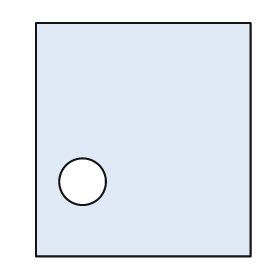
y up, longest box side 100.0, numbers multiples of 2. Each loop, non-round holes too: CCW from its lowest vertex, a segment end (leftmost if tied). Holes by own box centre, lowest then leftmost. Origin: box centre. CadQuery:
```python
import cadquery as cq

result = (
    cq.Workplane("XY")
    .moveTo(-46.0, -50.0)
    .lineTo(46.0, -50.0)
    .lineTo(46.0, 50.0)
    .lineTo(-46.0, 50.0)
    .close()
    .moveTo(-26.0, -18.0)
    .circle(10.0)
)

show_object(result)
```